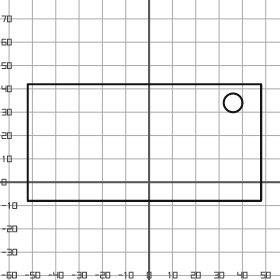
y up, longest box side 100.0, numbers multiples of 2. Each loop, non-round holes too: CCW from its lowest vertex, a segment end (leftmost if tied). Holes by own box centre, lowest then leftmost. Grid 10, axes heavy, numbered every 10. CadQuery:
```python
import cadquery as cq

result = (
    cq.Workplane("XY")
    .moveTo(-52.0, -8.0)
    .lineTo(48.0, -8.0)
    .lineTo(48.0, 42.0)
    .lineTo(-52.0, 42.0)
    .close()
    .moveTo(36.0, 34.0)
    .circle(4.0)
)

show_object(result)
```